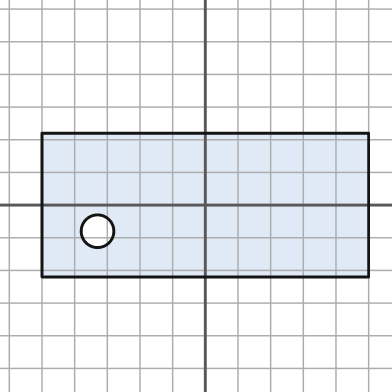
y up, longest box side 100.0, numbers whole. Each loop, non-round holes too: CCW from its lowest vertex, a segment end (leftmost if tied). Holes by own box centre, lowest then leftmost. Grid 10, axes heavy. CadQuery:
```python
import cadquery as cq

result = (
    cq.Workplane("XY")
    .moveTo(-50.0, -22.0)
    .lineTo(50.0, -22.0)
    .lineTo(50.0, 22.0)
    .lineTo(-50.0, 22.0)
    .close()
    .moveTo(-33.0, -8.0)
    .circle(5.0)
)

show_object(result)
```